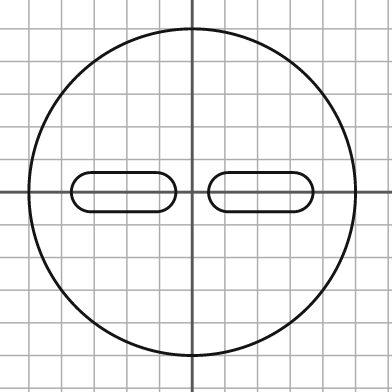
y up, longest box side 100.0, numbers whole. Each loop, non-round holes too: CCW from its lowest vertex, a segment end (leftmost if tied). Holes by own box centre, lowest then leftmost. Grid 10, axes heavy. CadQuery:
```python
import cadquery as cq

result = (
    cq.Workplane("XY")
    .moveTo(0.0, 0.0)
    .circle(50.0)
    .moveTo(-31.0, -6.0)
    .lineTo(-11.0, -6.0)
    .threePointArc((-5.0, 0.0), (-11.0, 6.0))
    .lineTo(-31.0, 6.0)
    .threePointArc((-37.0, 0.0), (-31.0, -6.0))
    .close()
    .moveTo(11.0, -6.0)
    .lineTo(31.0, -6.0)
    .threePointArc((37.0, 0.0), (31.0, 6.0))
    .lineTo(11.0, 6.0)
    .threePointArc((5.0, 0.0), (11.0, -6.0))
    .close()
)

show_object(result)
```